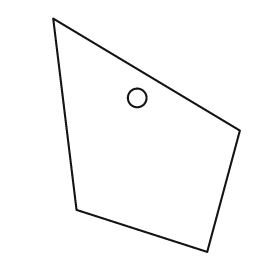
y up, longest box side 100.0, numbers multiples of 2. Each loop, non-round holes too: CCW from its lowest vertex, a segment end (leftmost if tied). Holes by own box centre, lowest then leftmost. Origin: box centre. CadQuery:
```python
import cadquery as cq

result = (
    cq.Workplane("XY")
    .moveTo(26.0, -50.0)
    .lineTo(40.0, 2.0)
    .lineTo(-40.0, 50.0)
    .lineTo(-30.0, -32.0)
    .close()
    .moveTo(-4.0, 16.0)
    .circle(4.0)
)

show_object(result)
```